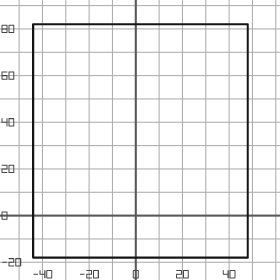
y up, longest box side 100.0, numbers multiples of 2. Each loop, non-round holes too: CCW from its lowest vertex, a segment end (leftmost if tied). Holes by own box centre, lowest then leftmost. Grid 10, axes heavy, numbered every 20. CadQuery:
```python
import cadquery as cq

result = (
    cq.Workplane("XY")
    .moveTo(-44.0, -18.0)
    .lineTo(48.0, -18.0)
    .lineTo(48.0, 82.0)
    .lineTo(-44.0, 82.0)
    .close()
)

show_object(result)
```